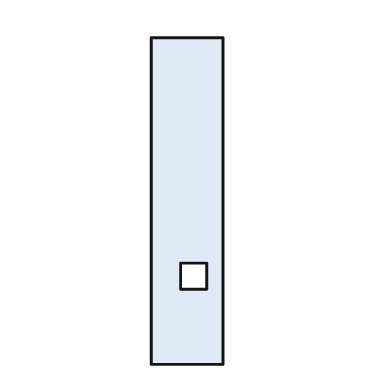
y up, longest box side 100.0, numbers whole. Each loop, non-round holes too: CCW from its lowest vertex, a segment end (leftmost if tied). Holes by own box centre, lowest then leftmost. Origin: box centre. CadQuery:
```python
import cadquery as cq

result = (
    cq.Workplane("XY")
    .moveTo(-11.0, -50.0)
    .lineTo(11.0, -50.0)
    .lineTo(11.0, 50.0)
    .lineTo(-11.0, 50.0)
    .close()
    .moveTo(-2.0, -27.0)
    .lineTo(6.0, -27.0)
    .lineTo(6.0, -19.0)
    .lineTo(-2.0, -19.0)
    .close()
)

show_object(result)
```